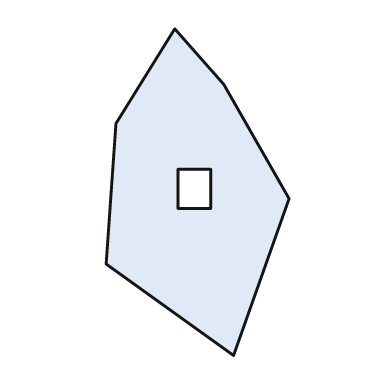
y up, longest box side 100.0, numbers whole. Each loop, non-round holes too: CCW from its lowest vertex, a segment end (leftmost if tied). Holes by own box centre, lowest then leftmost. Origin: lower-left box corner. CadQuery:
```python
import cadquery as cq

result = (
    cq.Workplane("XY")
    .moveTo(39.0, 0.0)
    .lineTo(56.0, 48.0)
    .lineTo(36.0, 83.0)
    .lineTo(21.0, 100.0)
    .lineTo(3.0, 71.0)
    .lineTo(0.0, 28.0)
    .close()
    .moveTo(22.0, 45.0)
    .lineTo(32.0, 45.0)
    .lineTo(32.0, 57.0)
    .lineTo(22.0, 57.0)
    .close()
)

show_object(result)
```